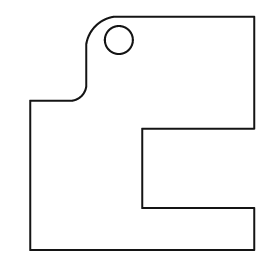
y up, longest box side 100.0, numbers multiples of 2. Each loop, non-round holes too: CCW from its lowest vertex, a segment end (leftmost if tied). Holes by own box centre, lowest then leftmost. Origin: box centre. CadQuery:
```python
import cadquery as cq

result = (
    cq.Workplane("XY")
    .moveTo(-48.0, -50.0)
    .lineTo(48.0, -50.0)
    .lineTo(48.0, -32.0)
    .lineTo(0.0, -32.0)
    .lineTo(0.0, 2.0)
    .lineTo(48.0, 2.0)
    .lineTo(48.0, 50.0)
    .lineTo(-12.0, 50.0)
    .threePointArc((-20.0, 46.0), (-24.0, 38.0))
    .lineTo(-24.0, 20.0)
    .threePointArc((-26.0, 16.0), (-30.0, 14.0))
    .lineTo(-48.0, 14.0)
    .close()
    .moveTo(-10.0, 40.0)
    .circle(6.0)
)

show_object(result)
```